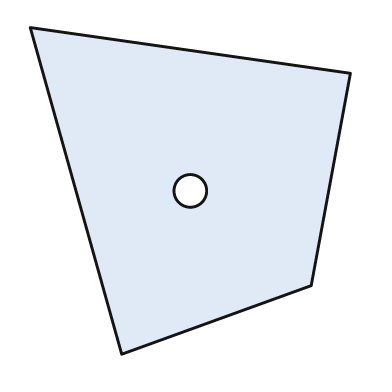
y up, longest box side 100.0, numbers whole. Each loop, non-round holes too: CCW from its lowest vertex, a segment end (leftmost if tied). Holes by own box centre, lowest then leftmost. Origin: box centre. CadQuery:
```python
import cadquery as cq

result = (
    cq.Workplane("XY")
    .moveTo(-21.0, -50.0)
    .lineTo(37.0, -29.0)
    .lineTo(49.0, 36.0)
    .lineTo(-49.0, 50.0)
    .close()
    .moveTo(0.0, 0.0)
    .circle(5.0)
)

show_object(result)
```